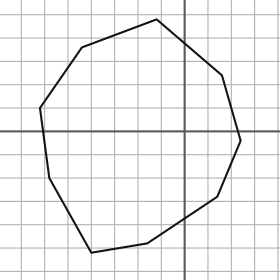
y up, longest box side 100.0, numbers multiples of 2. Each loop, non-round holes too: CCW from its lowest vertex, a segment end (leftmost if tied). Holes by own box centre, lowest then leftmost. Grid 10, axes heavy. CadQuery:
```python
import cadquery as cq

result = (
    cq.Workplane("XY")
    .moveTo(-40.0, -52.0)
    .lineTo(-16.0, -48.0)
    .lineTo(14.0, -28.0)
    .lineTo(24.0, -4.0)
    .lineTo(16.0, 24.0)
    .lineTo(-12.0, 48.0)
    .lineTo(-44.0, 36.0)
    .lineTo(-62.0, 10.0)
    .lineTo(-58.0, -20.0)
    .close()
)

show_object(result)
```